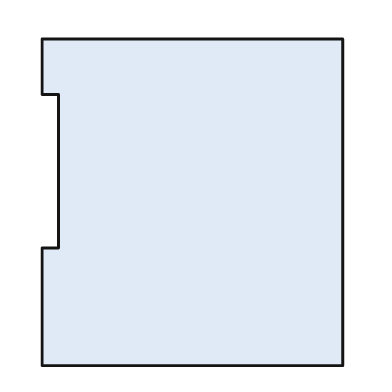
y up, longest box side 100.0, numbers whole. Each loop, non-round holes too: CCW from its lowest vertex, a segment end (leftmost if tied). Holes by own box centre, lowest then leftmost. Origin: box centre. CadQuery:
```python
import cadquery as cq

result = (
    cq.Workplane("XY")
    .moveTo(-46.0, -50.0)
    .lineTo(46.0, -50.0)
    .lineTo(46.0, 50.0)
    .lineTo(-46.0, 50.0)
    .lineTo(-46.0, 33.0)
    .lineTo(-41.0, 33.0)
    .lineTo(-41.0, -14.0)
    .lineTo(-46.0, -14.0)
    .close()
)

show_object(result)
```